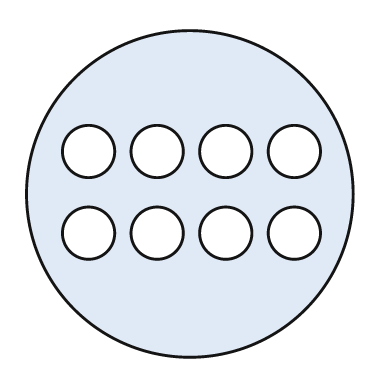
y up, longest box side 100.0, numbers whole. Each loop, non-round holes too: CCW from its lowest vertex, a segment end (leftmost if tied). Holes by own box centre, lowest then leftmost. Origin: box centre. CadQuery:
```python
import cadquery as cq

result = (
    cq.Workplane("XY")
    .moveTo(0.0, 0.0)
    .circle(50.0)
    .moveTo(-31.0, -12.0)
    .circle(8.0)
    .moveTo(-10.0, -12.0)
    .circle(8.0)
    .moveTo(11.0, -12.0)
    .circle(8.0)
    .moveTo(32.0, -12.0)
    .circle(8.0)
    .moveTo(-31.0, 13.0)
    .circle(8.0)
    .moveTo(-10.0, 13.0)
    .circle(8.0)
    .moveTo(11.0, 13.0)
    .circle(8.0)
    .moveTo(32.0, 13.0)
    .circle(8.0)
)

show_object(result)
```